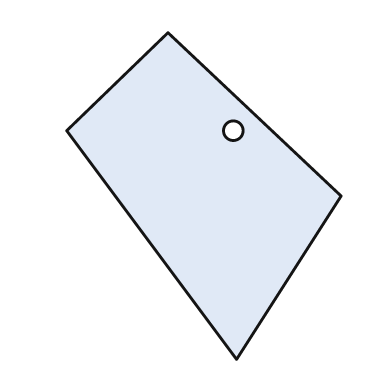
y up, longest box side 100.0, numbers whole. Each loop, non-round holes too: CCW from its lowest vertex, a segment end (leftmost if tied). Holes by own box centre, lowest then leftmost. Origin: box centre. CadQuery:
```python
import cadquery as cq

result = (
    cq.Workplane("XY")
    .moveTo(10.0, -50.0)
    .lineTo(42.0, 0.0)
    .lineTo(-11.0, 50.0)
    .lineTo(-42.0, 20.0)
    .close()
    .moveTo(9.0, 20.0)
    .circle(3.0)
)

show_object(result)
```